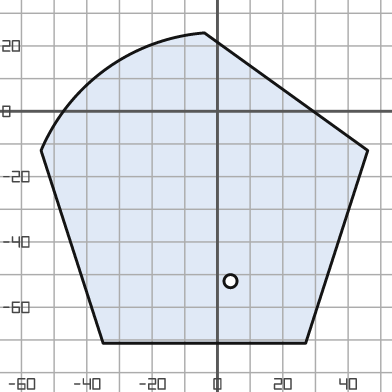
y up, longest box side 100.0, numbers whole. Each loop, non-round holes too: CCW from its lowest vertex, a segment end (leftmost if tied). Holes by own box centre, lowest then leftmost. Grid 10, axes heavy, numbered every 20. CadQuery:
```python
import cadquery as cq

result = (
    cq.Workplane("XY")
    .moveTo(-35.0, -71.0)
    .lineTo(27.0, -71.0)
    .lineTo(46.0, -12.0)
    .lineTo(-4.0, 24.0)
    .threePointArc((-34.0, 13.0), (-54.0, -12.0))
    .close()
    .moveTo(4.0, -52.0)
    .circle(2.0)
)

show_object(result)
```